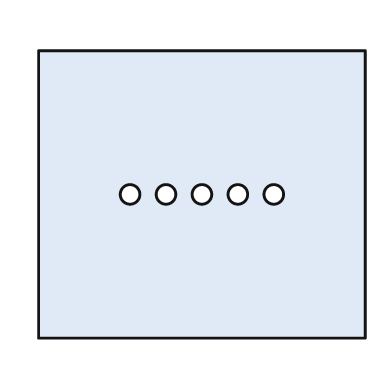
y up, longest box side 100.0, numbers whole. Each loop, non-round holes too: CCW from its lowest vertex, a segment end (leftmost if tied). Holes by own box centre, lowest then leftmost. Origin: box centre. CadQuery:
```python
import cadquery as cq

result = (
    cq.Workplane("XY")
    .moveTo(-50.0, -44.0)
    .lineTo(50.0, -44.0)
    .lineTo(50.0, 44.0)
    .lineTo(-50.0, 44.0)
    .close()
    .moveTo(-22.0, 0.0)
    .circle(3.0)
    .moveTo(-11.0, 0.0)
    .circle(3.0)
    .moveTo(0.0, 0.0)
    .circle(3.0)
    .moveTo(11.0, 0.0)
    .circle(3.0)
    .moveTo(22.0, 0.0)
    .circle(3.0)
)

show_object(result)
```